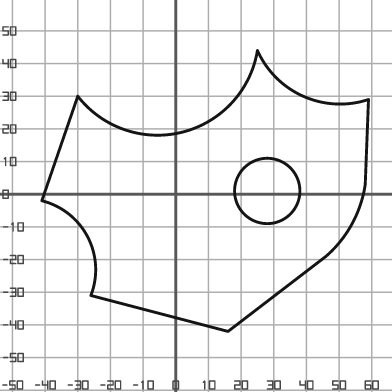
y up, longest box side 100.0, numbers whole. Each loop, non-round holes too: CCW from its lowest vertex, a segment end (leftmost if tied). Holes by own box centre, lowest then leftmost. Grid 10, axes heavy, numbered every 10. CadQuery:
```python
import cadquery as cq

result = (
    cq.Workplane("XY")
    .moveTo(16.0, -42.0)
    .lineTo(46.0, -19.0)
    .threePointArc((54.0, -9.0), (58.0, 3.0))
    .lineTo(59.0, 29.0)
    .threePointArc((39.0, 30.0), (25.0, 44.0))
    .threePointArc((2.0, 19.0), (-30.0, 30.0))
    .lineTo(-41.0, -2.0)
    .threePointArc((-27.0, -13.0), (-26.0, -31.0))
    .close()
    .moveTo(28.0, 1.0)
    .circle(10.0)
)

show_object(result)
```